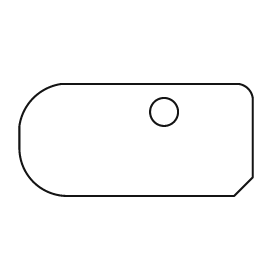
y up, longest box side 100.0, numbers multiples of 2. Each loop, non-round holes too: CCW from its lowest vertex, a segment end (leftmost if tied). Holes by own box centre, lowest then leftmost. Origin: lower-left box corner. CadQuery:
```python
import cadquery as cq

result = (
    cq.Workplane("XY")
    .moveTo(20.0, 0.0)
    .lineTo(92.0, 0.0)
    .lineTo(100.0, 8.0)
    .lineTo(100.0, 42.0)
    .threePointArc((98.0, 46.0), (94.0, 48.0))
    .lineTo(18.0, 48.0)
    .threePointArc((6.0, 42.0), (0.0, 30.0))
    .lineTo(0.0, 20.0)
    .threePointArc((6.0, 6.0), (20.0, 0.0))
    .close()
    .moveTo(62.0, 36.0)
    .circle(6.0)
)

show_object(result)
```